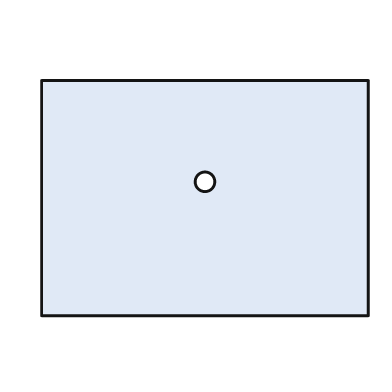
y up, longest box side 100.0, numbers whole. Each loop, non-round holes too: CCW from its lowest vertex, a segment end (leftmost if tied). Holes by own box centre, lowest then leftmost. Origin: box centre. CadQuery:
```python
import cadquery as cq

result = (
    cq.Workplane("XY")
    .moveTo(-50.0, -36.0)
    .lineTo(50.0, -36.0)
    .lineTo(50.0, 36.0)
    .lineTo(-50.0, 36.0)
    .close()
    .moveTo(0.0, 5.0)
    .circle(3.0)
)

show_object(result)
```